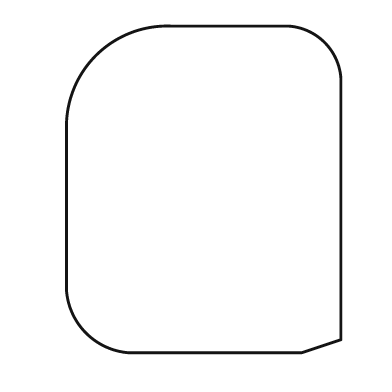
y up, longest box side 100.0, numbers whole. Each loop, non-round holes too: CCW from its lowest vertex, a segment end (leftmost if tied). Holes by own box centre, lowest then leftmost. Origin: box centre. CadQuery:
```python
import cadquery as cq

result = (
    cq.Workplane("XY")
    .moveTo(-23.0, -50.0)
    .lineTo(30.0, -50.0)
    .lineTo(42.0, -46.0)
    .lineTo(42.0, 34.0)
    .threePointArc((37.0, 45.0), (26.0, 50.0))
    .lineTo(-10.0, 50.0)
    .threePointArc((-33.0, 41.0), (-42.0, 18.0))
    .lineTo(-42.0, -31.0)
    .threePointArc((-36.0, -44.0), (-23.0, -50.0))
    .close()
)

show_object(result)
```